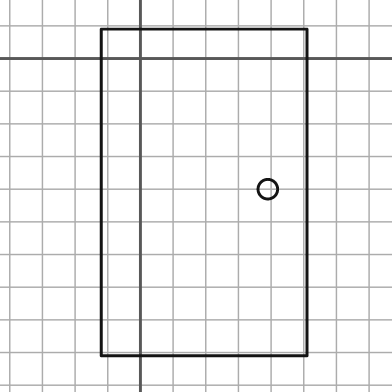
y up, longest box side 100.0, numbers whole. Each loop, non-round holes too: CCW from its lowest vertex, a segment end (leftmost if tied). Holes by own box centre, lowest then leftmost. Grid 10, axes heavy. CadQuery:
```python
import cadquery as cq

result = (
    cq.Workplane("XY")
    .moveTo(-12.0, -91.0)
    .lineTo(51.0, -91.0)
    .lineTo(51.0, 9.0)
    .lineTo(-12.0, 9.0)
    .close()
    .moveTo(39.0, -40.0)
    .circle(3.0)
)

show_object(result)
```